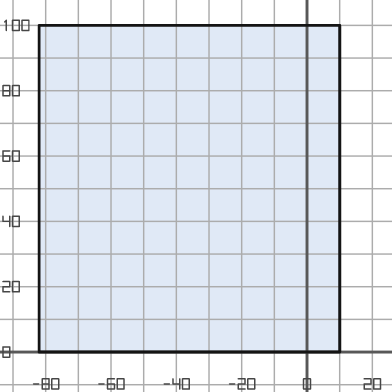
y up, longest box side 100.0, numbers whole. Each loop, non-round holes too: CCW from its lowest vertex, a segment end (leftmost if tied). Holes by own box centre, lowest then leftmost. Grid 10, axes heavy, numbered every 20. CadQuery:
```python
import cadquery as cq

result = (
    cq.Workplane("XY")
    .moveTo(-82.0, 0.0)
    .lineTo(10.0, 0.0)
    .lineTo(10.0, 100.0)
    .lineTo(-82.0, 100.0)
    .close()
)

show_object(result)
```